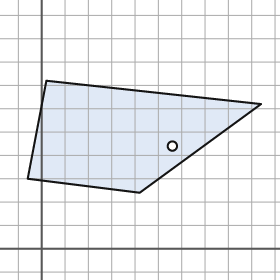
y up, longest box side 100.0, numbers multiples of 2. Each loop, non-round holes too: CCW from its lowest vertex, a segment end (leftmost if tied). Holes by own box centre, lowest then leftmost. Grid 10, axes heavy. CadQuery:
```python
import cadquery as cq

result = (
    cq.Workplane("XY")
    .moveTo(42.0, 24.0)
    .lineTo(94.0, 62.0)
    .lineTo(2.0, 72.0)
    .lineTo(-6.0, 30.0)
    .close()
    .moveTo(56.0, 44.0)
    .circle(2.0)
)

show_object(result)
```